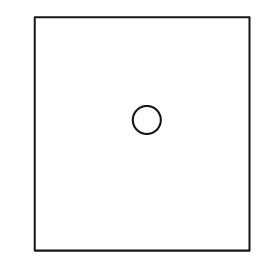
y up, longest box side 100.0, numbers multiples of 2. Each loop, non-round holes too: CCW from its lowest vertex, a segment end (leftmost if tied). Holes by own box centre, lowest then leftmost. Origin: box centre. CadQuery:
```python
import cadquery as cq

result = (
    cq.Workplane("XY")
    .moveTo(-46.0, -50.0)
    .lineTo(46.0, -50.0)
    .lineTo(46.0, 50.0)
    .lineTo(-46.0, 50.0)
    .close()
    .moveTo(2.0, 6.0)
    .circle(6.0)
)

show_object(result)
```